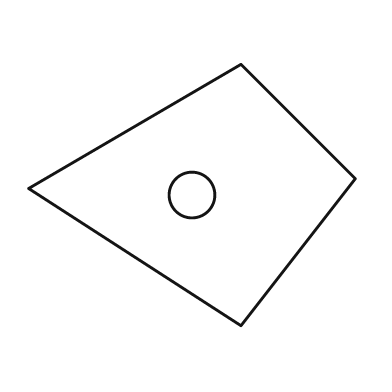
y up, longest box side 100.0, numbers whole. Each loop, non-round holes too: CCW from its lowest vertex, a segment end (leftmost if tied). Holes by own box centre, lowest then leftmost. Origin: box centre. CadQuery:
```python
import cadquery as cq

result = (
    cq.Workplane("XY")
    .moveTo(15.0, -40.0)
    .lineTo(50.0, 5.0)
    .lineTo(15.0, 40.0)
    .lineTo(-50.0, 2.0)
    .close()
    .moveTo(0.0, 0.0)
    .circle(7.0)
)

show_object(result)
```